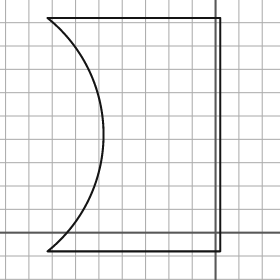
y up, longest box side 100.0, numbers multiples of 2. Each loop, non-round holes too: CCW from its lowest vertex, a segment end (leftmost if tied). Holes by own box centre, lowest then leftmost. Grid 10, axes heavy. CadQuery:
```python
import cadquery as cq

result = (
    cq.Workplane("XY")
    .moveTo(-72.0, -8.0)
    .lineTo(2.0, -8.0)
    .lineTo(2.0, 92.0)
    .lineTo(-72.0, 92.0)
    .threePointArc((-48.0, 42.0), (-72.0, -8.0))
    .close()
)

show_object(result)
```